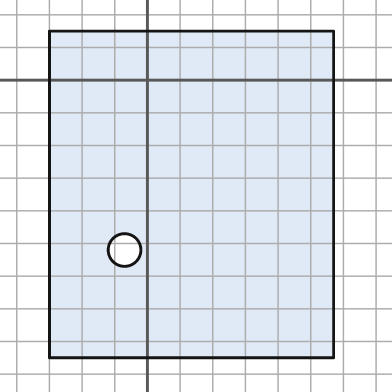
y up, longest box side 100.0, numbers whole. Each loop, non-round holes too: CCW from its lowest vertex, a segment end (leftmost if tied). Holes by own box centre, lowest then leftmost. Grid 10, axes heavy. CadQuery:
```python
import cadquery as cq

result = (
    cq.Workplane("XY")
    .moveTo(-30.0, -85.0)
    .lineTo(57.0, -85.0)
    .lineTo(57.0, 15.0)
    .lineTo(-30.0, 15.0)
    .close()
    .moveTo(-7.0, -52.0)
    .circle(5.0)
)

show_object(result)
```